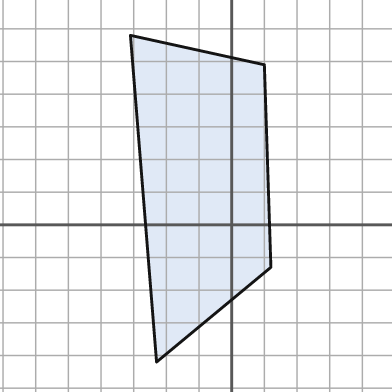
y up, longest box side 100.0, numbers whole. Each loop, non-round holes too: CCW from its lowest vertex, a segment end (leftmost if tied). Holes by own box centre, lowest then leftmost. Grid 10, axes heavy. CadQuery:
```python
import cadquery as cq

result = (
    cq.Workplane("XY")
    .moveTo(-23.0, -42.0)
    .lineTo(12.0, -13.0)
    .lineTo(10.0, 49.0)
    .lineTo(-31.0, 58.0)
    .close()
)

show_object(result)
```